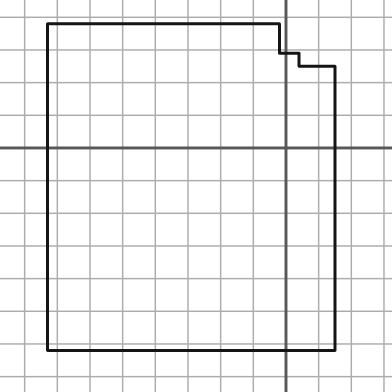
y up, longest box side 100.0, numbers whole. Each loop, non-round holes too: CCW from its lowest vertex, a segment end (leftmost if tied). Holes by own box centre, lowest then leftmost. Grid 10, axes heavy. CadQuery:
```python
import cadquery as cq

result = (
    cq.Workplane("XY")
    .moveTo(-73.0, -62.0)
    .lineTo(15.0, -62.0)
    .lineTo(15.0, 25.0)
    .lineTo(4.0, 25.0)
    .lineTo(4.0, 29.0)
    .lineTo(-2.0, 29.0)
    .lineTo(-2.0, 38.0)
    .lineTo(-73.0, 38.0)
    .close()
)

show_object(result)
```